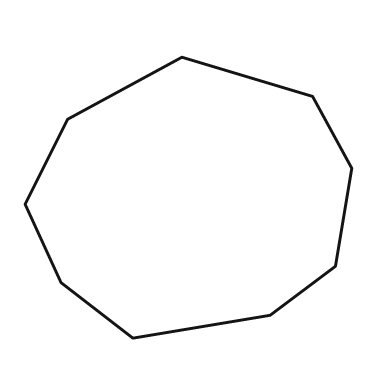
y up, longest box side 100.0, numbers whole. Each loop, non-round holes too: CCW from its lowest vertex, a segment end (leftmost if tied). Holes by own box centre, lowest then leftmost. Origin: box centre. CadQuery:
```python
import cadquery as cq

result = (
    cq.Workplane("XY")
    .moveTo(-17.0, -43.0)
    .lineTo(25.0, -36.0)
    .lineTo(45.0, -21.0)
    .lineTo(50.0, 9.0)
    .lineTo(38.0, 31.0)
    .lineTo(-2.0, 43.0)
    .lineTo(-37.0, 24.0)
    .lineTo(-50.0, -2.0)
    .lineTo(-39.0, -26.0)
    .close()
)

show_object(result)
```